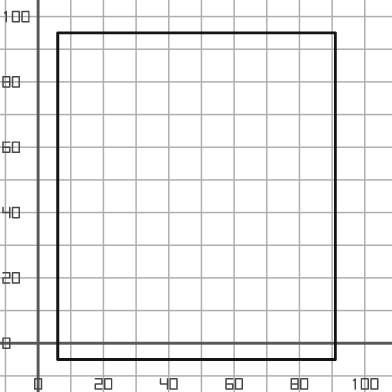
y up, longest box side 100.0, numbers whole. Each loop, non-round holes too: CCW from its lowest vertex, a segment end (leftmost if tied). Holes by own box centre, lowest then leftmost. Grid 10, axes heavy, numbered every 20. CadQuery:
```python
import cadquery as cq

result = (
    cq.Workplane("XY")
    .moveTo(6.0, -5.0)
    .lineTo(91.0, -5.0)
    .lineTo(91.0, 95.0)
    .lineTo(6.0, 95.0)
    .close()
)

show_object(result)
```